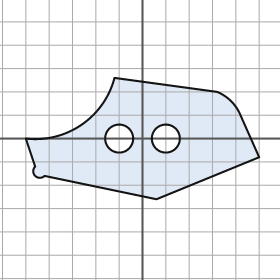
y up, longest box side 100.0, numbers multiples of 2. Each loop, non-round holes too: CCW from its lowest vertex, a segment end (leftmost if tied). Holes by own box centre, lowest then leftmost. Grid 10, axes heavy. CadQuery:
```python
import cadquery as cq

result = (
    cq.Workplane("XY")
    .moveTo(6.0, -26.0)
    .lineTo(50.0, -8.0)
    .lineTo(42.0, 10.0)
    .threePointArc((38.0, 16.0), (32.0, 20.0))
    .lineTo(-12.0, 26.0)
    .threePointArc((-26.0, 6.0), (-50.0, 0.0))
    .lineTo(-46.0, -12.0)
    .threePointArc((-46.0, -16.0), (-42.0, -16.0))
    .close()
    .moveTo(-10.0, 0.0)
    .circle(6.0)
    .moveTo(10.0, 0.0)
    .circle(6.0)
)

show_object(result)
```